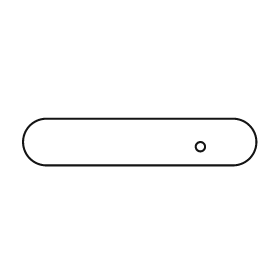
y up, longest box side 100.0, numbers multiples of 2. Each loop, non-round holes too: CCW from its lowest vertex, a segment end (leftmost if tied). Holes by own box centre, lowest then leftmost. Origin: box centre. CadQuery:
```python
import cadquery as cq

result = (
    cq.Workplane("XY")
    .moveTo(-40.0, -10.0)
    .lineTo(40.0, -10.0)
    .threePointArc((50.0, 0.0), (40.0, 10.0))
    .lineTo(-40.0, 10.0)
    .threePointArc((-50.0, 0.0), (-40.0, -10.0))
    .close()
    .moveTo(26.0, -2.0)
    .circle(2.0)
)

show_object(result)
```